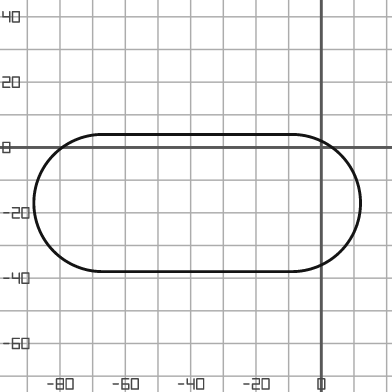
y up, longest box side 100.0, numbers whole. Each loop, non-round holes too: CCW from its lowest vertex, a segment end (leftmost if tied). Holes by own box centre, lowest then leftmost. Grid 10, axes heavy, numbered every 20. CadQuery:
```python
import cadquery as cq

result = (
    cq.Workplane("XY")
    .moveTo(-67.0, -38.0)
    .lineTo(-9.0, -38.0)
    .threePointArc((12.0, -17.0), (-9.0, 4.0))
    .lineTo(-67.0, 4.0)
    .threePointArc((-88.0, -17.0), (-67.0, -38.0))
    .close()
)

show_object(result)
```